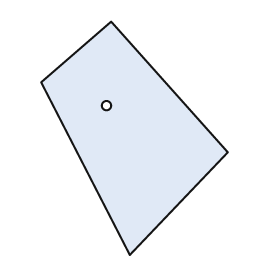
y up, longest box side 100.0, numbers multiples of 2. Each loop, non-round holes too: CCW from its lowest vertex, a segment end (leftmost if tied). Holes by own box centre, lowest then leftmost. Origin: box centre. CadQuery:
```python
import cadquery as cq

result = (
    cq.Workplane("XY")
    .moveTo(-2.0, -50.0)
    .lineTo(40.0, -6.0)
    .lineTo(-10.0, 50.0)
    .lineTo(-40.0, 24.0)
    .close()
    .moveTo(-12.0, 14.0)
    .circle(2.0)
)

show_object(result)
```